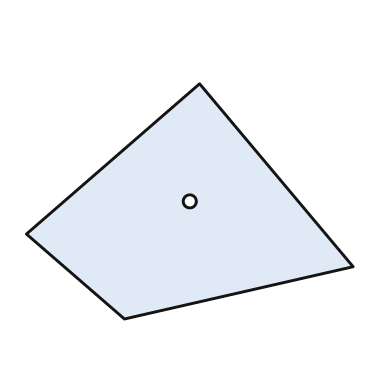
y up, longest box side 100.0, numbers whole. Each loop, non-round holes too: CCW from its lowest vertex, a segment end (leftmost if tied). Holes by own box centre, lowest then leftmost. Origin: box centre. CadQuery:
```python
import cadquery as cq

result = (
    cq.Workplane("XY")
    .moveTo(-20.0, -36.0)
    .lineTo(50.0, -20.0)
    .lineTo(3.0, 36.0)
    .lineTo(-50.0, -10.0)
    .close()
    .moveTo(0.0, 0.0)
    .circle(2.0)
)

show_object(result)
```